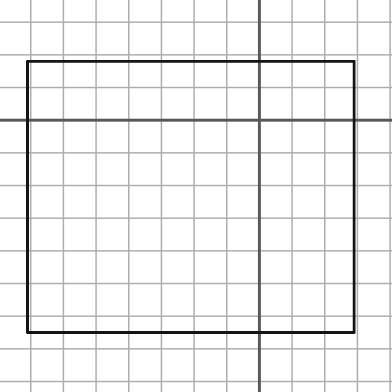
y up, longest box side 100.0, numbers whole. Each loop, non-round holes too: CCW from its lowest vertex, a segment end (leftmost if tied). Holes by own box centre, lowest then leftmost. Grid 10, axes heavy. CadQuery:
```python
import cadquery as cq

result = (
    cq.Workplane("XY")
    .moveTo(-71.0, -65.0)
    .lineTo(29.0, -65.0)
    .lineTo(29.0, 18.0)
    .lineTo(-71.0, 18.0)
    .close()
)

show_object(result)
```